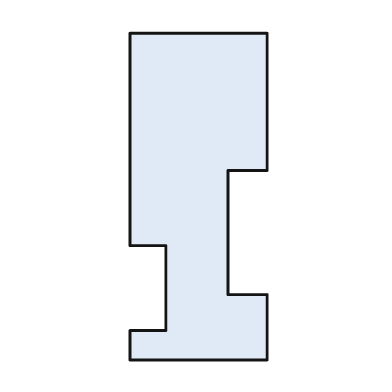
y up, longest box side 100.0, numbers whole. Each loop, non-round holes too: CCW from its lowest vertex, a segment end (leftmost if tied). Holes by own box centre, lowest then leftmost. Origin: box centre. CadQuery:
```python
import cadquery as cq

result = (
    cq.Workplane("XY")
    .moveTo(-21.0, -50.0)
    .lineTo(21.0, -50.0)
    .lineTo(21.0, -30.0)
    .lineTo(9.0, -30.0)
    .lineTo(9.0, 8.0)
    .lineTo(21.0, 8.0)
    .lineTo(21.0, 50.0)
    .lineTo(-21.0, 50.0)
    .lineTo(-21.0, -15.0)
    .lineTo(-10.0, -15.0)
    .lineTo(-10.0, -41.0)
    .lineTo(-21.0, -41.0)
    .close()
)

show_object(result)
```